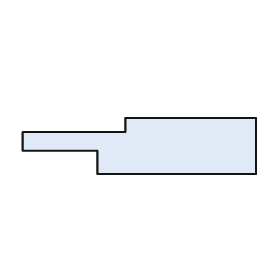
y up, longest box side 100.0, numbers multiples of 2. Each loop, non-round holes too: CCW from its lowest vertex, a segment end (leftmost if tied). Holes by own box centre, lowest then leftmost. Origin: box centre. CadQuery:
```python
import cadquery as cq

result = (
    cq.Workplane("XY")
    .moveTo(-18.0, -12.0)
    .lineTo(50.0, -12.0)
    .lineTo(50.0, 12.0)
    .lineTo(-6.0, 12.0)
    .lineTo(-6.0, 6.0)
    .lineTo(-50.0, 6.0)
    .lineTo(-50.0, -2.0)
    .lineTo(-18.0, -2.0)
    .close()
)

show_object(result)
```